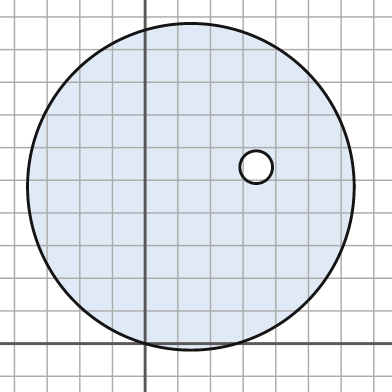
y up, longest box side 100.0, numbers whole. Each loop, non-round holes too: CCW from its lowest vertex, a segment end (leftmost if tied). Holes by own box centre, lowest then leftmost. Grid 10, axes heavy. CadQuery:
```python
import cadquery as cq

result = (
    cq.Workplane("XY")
    .moveTo(14.0, 48.0)
    .circle(50.0)
    .moveTo(34.0, 54.0)
    .circle(5.0)
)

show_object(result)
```